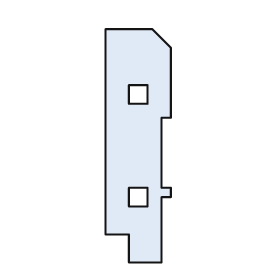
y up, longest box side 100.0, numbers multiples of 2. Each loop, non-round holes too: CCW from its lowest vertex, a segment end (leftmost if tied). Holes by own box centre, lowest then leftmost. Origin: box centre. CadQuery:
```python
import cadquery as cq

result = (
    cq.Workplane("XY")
    .moveTo(-4.0, -50.0)
    .lineTo(10.0, -50.0)
    .lineTo(10.0, -22.0)
    .lineTo(14.0, -22.0)
    .lineTo(14.0, -18.0)
    .lineTo(10.0, -18.0)
    .lineTo(10.0, 12.0)
    .lineTo(14.0, 12.0)
    .lineTo(14.0, 42.0)
    .lineTo(6.0, 50.0)
    .lineTo(-14.0, 50.0)
    .lineTo(-14.0, -38.0)
    .lineTo(-4.0, -38.0)
    .close()
    .moveTo(-4.0, -26.0)
    .lineTo(4.0, -26.0)
    .lineTo(4.0, -18.0)
    .lineTo(-4.0, -18.0)
    .close()
    .moveTo(-4.0, 18.0)
    .lineTo(4.0, 18.0)
    .lineTo(4.0, 26.0)
    .lineTo(-4.0, 26.0)
    .close()
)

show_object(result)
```